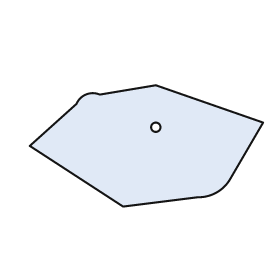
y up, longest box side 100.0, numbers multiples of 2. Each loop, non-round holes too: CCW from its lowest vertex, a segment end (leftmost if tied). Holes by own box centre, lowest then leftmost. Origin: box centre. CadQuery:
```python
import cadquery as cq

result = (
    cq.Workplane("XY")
    .moveTo(-10.0, -26.0)
    .lineTo(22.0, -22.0)
    .threePointArc((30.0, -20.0), (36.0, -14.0))
    .lineTo(50.0, 10.0)
    .lineTo(4.0, 26.0)
    .lineTo(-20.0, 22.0)
    .threePointArc((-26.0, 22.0), (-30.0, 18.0))
    .lineTo(-50.0, 0.0)
    .close()
    .moveTo(4.0, 8.0)
    .circle(2.0)
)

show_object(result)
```